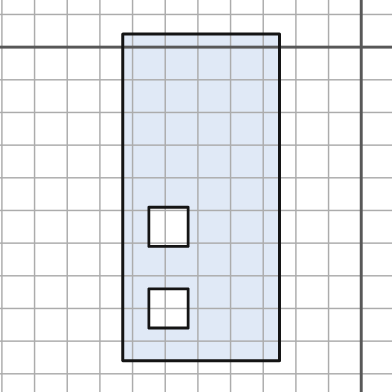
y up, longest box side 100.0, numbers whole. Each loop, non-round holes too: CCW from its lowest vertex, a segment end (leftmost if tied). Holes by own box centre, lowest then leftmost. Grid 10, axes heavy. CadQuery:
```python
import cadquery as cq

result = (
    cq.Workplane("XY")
    .moveTo(-73.0, -96.0)
    .lineTo(-25.0, -96.0)
    .lineTo(-25.0, 4.0)
    .lineTo(-73.0, 4.0)
    .close()
    .moveTo(-65.0, -86.0)
    .lineTo(-53.0, -86.0)
    .lineTo(-53.0, -74.0)
    .lineTo(-65.0, -74.0)
    .close()
    .moveTo(-65.0, -61.0)
    .lineTo(-53.0, -61.0)
    .lineTo(-53.0, -49.0)
    .lineTo(-65.0, -49.0)
    .close()
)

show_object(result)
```